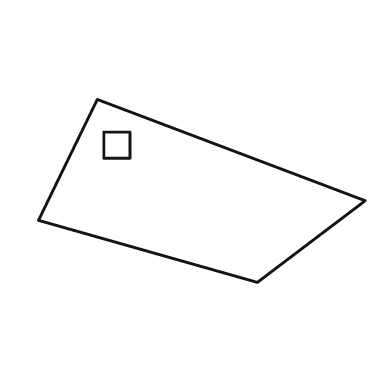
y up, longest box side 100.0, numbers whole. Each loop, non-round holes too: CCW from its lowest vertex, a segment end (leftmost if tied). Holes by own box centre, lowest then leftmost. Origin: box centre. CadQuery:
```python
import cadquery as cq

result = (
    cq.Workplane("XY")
    .moveTo(17.0, -28.0)
    .lineTo(50.0, -3.0)
    .lineTo(-32.0, 28.0)
    .lineTo(-50.0, -9.0)
    .close()
    .moveTo(-30.0, 10.0)
    .lineTo(-22.0, 10.0)
    .lineTo(-22.0, 18.0)
    .lineTo(-30.0, 18.0)
    .close()
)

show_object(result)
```